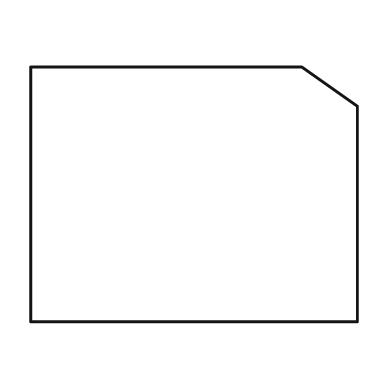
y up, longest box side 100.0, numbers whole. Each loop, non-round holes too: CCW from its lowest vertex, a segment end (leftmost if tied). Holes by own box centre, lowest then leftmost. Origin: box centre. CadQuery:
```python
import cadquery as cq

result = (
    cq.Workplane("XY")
    .moveTo(-50.0, -39.0)
    .lineTo(50.0, -39.0)
    .lineTo(50.0, 27.0)
    .lineTo(33.0, 39.0)
    .lineTo(-50.0, 39.0)
    .close()
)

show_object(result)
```